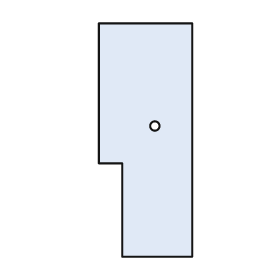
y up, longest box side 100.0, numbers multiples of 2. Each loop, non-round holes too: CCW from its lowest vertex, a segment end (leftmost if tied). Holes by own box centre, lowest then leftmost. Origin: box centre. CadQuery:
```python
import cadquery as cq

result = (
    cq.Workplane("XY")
    .moveTo(-10.0, -50.0)
    .lineTo(20.0, -50.0)
    .lineTo(20.0, 50.0)
    .lineTo(-20.0, 50.0)
    .lineTo(-20.0, -10.0)
    .lineTo(-10.0, -10.0)
    .close()
    .moveTo(4.0, 6.0)
    .circle(2.0)
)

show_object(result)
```